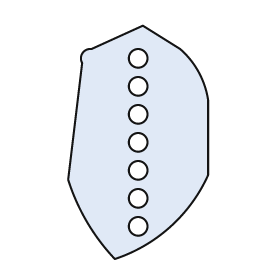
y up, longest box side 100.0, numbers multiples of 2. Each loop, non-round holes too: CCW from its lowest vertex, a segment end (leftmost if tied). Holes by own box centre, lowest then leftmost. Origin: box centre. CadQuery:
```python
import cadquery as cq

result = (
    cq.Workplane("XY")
    .moveTo(-10.0, -50.0)
    .threePointArc((14.0, -36.0), (30.0, -14.0))
    .lineTo(30.0, 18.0)
    .threePointArc((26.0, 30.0), (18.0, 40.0))
    .lineTo(2.0, 50.0)
    .lineTo(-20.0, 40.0)
    .threePointArc((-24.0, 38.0), (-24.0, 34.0))
    .lineTo(-30.0, -16.0)
    .threePointArc((-22.0, -34.0), (-10.0, -50.0))
    .close()
    .moveTo(0.0, -36.0)
    .circle(4.0)
    .moveTo(0.0, -24.0)
    .circle(4.0)
    .moveTo(0.0, -12.0)
    .circle(4.0)
    .moveTo(0.0, 0.0)
    .circle(4.0)
    .moveTo(0.0, 12.0)
    .circle(4.0)
    .moveTo(0.0, 24.0)
    .circle(4.0)
    .moveTo(0.0, 36.0)
    .circle(4.0)
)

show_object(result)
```